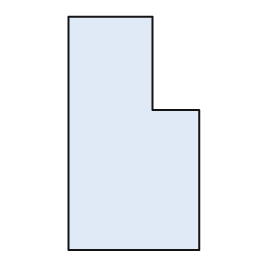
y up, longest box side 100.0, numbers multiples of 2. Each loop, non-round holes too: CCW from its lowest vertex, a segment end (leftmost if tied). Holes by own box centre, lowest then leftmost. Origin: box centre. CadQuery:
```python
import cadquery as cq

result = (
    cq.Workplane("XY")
    .moveTo(-28.0, -50.0)
    .lineTo(28.0, -50.0)
    .lineTo(28.0, 10.0)
    .lineTo(8.0, 10.0)
    .lineTo(8.0, 50.0)
    .lineTo(-28.0, 50.0)
    .close()
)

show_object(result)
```